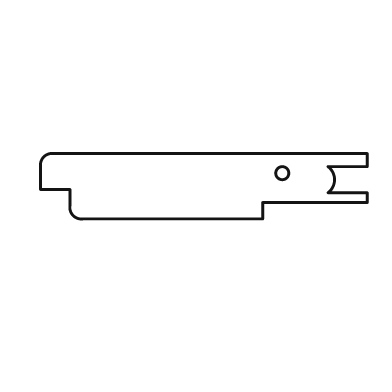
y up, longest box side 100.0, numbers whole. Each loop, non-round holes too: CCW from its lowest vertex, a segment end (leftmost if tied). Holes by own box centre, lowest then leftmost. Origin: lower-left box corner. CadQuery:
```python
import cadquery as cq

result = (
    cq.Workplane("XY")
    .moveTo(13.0, 0.0)
    .lineTo(68.0, 0.0)
    .lineTo(68.0, 5.0)
    .lineTo(100.0, 5.0)
    .lineTo(100.0, 8.0)
    .lineTo(88.0, 8.0)
    .threePointArc((90.0, 12.0), (88.0, 16.0))
    .lineTo(100.0, 16.0)
    .lineTo(100.0, 20.0)
    .lineTo(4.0, 20.0)
    .threePointArc((1.0, 19.0), (0.0, 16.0))
    .lineTo(0.0, 9.0)
    .lineTo(9.0, 9.0)
    .lineTo(9.0, 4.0)
    .threePointArc((10.0, 1.0), (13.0, 0.0))
    .close()
    .moveTo(74.0, 14.0)
    .circle(2.0)
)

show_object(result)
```